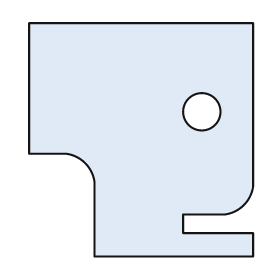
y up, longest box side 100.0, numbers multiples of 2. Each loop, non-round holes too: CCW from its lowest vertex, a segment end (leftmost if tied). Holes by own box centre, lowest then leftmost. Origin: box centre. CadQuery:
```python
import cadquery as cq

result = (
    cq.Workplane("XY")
    .moveTo(-20.0, -50.0)
    .lineTo(48.0, -50.0)
    .lineTo(48.0, -40.0)
    .lineTo(18.0, -40.0)
    .lineTo(18.0, -32.0)
    .lineTo(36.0, -32.0)
    .threePointArc((44.0, -28.0), (48.0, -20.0))
    .lineTo(48.0, 50.0)
    .lineTo(-48.0, 50.0)
    .lineTo(-48.0, -6.0)
    .lineTo(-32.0, -6.0)
    .threePointArc((-24.0, -10.0), (-20.0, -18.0))
    .close()
    .moveTo(26.0, 12.0)
    .circle(8.0)
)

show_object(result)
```